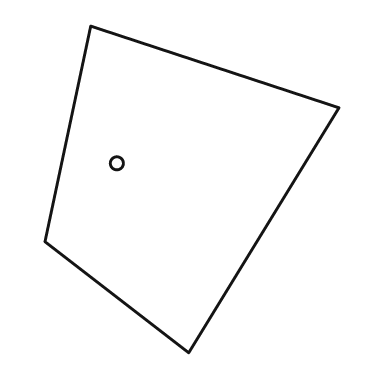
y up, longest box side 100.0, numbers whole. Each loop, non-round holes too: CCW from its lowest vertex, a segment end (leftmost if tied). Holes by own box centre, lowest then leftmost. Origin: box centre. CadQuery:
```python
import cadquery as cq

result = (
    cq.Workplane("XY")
    .moveTo(-1.0, -50.0)
    .lineTo(45.0, 25.0)
    .lineTo(-31.0, 50.0)
    .lineTo(-45.0, -16.0)
    .close()
    .moveTo(-23.0, 8.0)
    .circle(2.0)
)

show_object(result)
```